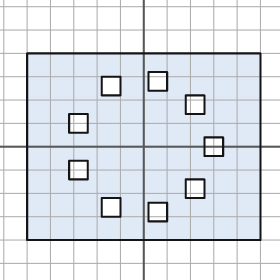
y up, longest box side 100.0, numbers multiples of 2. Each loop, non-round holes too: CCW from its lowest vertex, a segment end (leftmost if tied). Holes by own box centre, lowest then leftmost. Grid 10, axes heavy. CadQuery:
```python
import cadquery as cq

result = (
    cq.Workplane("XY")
    .moveTo(-50.0, -40.0)
    .lineTo(50.0, -40.0)
    .lineTo(50.0, 40.0)
    .lineTo(-50.0, 40.0)
    .close()
    .moveTo(2.0, -32.0)
    .lineTo(10.0, -32.0)
    .lineTo(10.0, -24.0)
    .lineTo(2.0, -24.0)
    .close()
    .moveTo(-18.0, -30.0)
    .lineTo(-10.0, -30.0)
    .lineTo(-10.0, -22.0)
    .lineTo(-18.0, -22.0)
    .close()
    .moveTo(18.0, -22.0)
    .lineTo(26.0, -22.0)
    .lineTo(26.0, -14.0)
    .lineTo(18.0, -14.0)
    .close()
    .moveTo(-32.0, -14.0)
    .lineTo(-24.0, -14.0)
    .lineTo(-24.0, -6.0)
    .lineTo(-32.0, -6.0)
    .close()
    .moveTo(26.0, -4.0)
    .lineTo(34.0, -4.0)
    .lineTo(34.0, 4.0)
    .lineTo(26.0, 4.0)
    .close()
    .moveTo(-32.0, 6.0)
    .lineTo(-24.0, 6.0)
    .lineTo(-24.0, 14.0)
    .lineTo(-32.0, 14.0)
    .close()
    .moveTo(18.0, 14.0)
    .lineTo(26.0, 14.0)
    .lineTo(26.0, 22.0)
    .lineTo(18.0, 22.0)
    .close()
    .moveTo(-18.0, 22.0)
    .lineTo(-10.0, 22.0)
    .lineTo(-10.0, 30.0)
    .lineTo(-18.0, 30.0)
    .close()
    .moveTo(2.0, 24.0)
    .lineTo(10.0, 24.0)
    .lineTo(10.0, 32.0)
    .lineTo(2.0, 32.0)
    .close()
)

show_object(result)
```